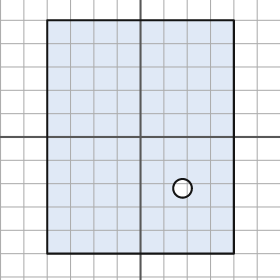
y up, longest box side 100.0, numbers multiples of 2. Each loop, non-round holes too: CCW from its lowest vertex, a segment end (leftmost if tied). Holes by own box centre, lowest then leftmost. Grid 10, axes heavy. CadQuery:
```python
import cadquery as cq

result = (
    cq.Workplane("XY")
    .moveTo(-40.0, -50.0)
    .lineTo(40.0, -50.0)
    .lineTo(40.0, 50.0)
    .lineTo(-40.0, 50.0)
    .close()
    .moveTo(18.0, -22.0)
    .circle(4.0)
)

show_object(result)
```